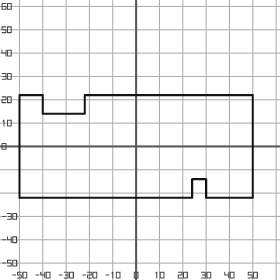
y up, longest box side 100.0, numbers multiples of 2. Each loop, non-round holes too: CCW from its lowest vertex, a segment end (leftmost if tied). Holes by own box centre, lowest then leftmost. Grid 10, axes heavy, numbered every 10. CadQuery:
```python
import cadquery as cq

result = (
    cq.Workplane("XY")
    .moveTo(-50.0, -22.0)
    .lineTo(24.0, -22.0)
    .lineTo(24.0, -14.0)
    .lineTo(30.0, -14.0)
    .lineTo(30.0, -22.0)
    .lineTo(50.0, -22.0)
    .lineTo(50.0, 22.0)
    .lineTo(-22.0, 22.0)
    .lineTo(-22.0, 14.0)
    .lineTo(-40.0, 14.0)
    .lineTo(-40.0, 22.0)
    .lineTo(-50.0, 22.0)
    .close()
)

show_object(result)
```